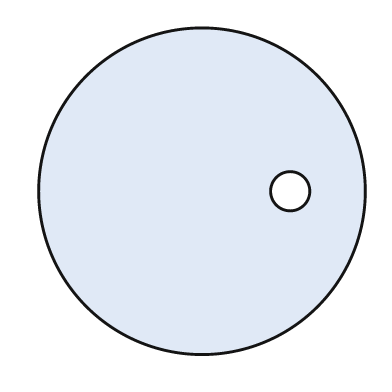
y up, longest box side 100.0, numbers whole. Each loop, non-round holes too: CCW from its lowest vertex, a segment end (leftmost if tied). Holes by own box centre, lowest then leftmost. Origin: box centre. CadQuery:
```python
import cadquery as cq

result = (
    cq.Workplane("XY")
    .moveTo(0.0, 0.0)
    .circle(50.0)
    .moveTo(27.0, 0.0)
    .circle(6.0)
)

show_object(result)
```